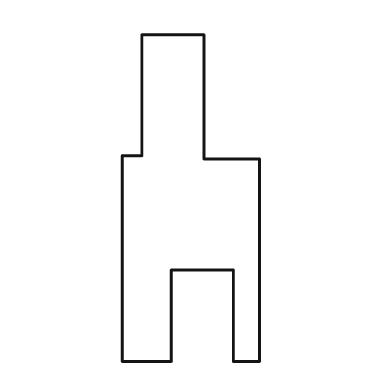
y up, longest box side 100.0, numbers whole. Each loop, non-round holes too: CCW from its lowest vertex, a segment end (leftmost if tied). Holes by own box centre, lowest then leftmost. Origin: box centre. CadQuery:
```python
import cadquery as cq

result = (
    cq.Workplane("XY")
    .moveTo(-21.0, -50.0)
    .lineTo(-6.0, -50.0)
    .lineTo(-6.0, -22.0)
    .lineTo(13.0, -22.0)
    .lineTo(13.0, -50.0)
    .lineTo(21.0, -50.0)
    .lineTo(21.0, 12.0)
    .lineTo(4.0, 12.0)
    .lineTo(4.0, 50.0)
    .lineTo(-15.0, 50.0)
    .lineTo(-15.0, 13.0)
    .lineTo(-21.0, 13.0)
    .close()
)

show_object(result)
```